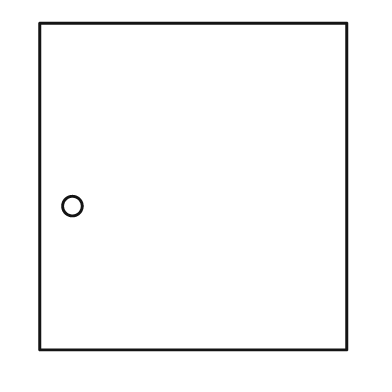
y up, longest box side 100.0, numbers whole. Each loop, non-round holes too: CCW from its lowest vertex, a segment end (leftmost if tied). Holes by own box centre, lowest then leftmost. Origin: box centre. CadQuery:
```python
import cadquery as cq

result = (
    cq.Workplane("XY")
    .moveTo(-47.0, -50.0)
    .lineTo(47.0, -50.0)
    .lineTo(47.0, 50.0)
    .lineTo(-47.0, 50.0)
    .close()
    .moveTo(-37.0, -6.0)
    .circle(3.0)
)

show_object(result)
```